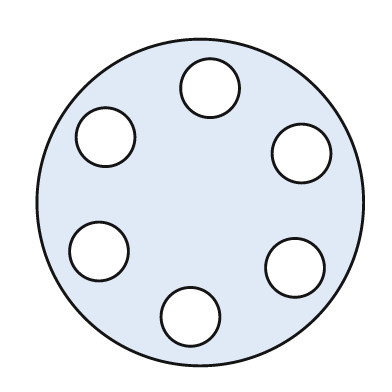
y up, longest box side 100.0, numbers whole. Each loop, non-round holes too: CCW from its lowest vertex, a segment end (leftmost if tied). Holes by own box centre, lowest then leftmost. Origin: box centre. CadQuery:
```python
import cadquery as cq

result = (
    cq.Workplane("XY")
    .moveTo(0.0, 0.0)
    .circle(50.0)
    .moveTo(-3.0, -35.0)
    .circle(9.0)
    .moveTo(29.0, -20.0)
    .circle(9.0)
    .moveTo(-31.0, -15.0)
    .circle(9.0)
    .moveTo(31.0, 15.0)
    .circle(9.0)
    .moveTo(-29.0, 20.0)
    .circle(9.0)
    .moveTo(3.0, 35.0)
    .circle(9.0)
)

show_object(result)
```